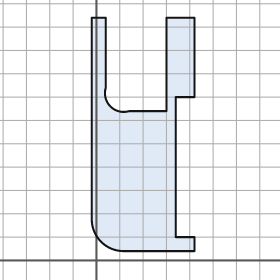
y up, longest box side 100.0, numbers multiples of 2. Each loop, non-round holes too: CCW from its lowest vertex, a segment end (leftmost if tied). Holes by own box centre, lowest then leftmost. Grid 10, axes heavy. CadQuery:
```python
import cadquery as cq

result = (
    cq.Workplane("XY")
    .moveTo(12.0, 4.0)
    .lineTo(42.0, 4.0)
    .lineTo(42.0, 10.0)
    .lineTo(34.0, 10.0)
    .lineTo(34.0, 70.0)
    .lineTo(42.0, 70.0)
    .lineTo(42.0, 104.0)
    .lineTo(30.0, 104.0)
    .lineTo(30.0, 64.0)
    .lineTo(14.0, 64.0)
    .threePointArc((6.0, 66.0), (4.0, 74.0))
    .lineTo(4.0, 104.0)
    .lineTo(-2.0, 104.0)
    .lineTo(-2.0, 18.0)
    .threePointArc((2.0, 8.0), (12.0, 4.0))
    .close()
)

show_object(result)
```